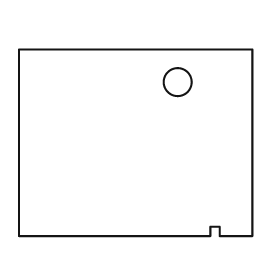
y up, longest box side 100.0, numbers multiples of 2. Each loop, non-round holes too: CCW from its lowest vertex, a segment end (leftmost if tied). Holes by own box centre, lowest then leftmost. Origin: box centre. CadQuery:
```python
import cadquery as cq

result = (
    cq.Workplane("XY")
    .moveTo(-50.0, -40.0)
    .lineTo(32.0, -40.0)
    .lineTo(32.0, -36.0)
    .lineTo(36.0, -36.0)
    .lineTo(36.0, -40.0)
    .lineTo(50.0, -40.0)
    .lineTo(50.0, 40.0)
    .lineTo(-50.0, 40.0)
    .close()
    .moveTo(18.0, 26.0)
    .circle(6.0)
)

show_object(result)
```